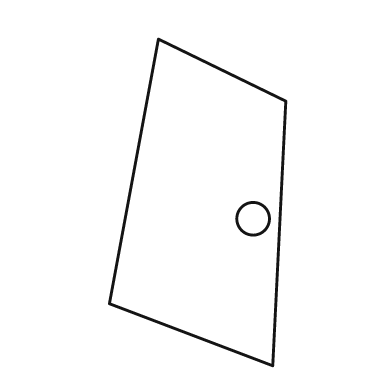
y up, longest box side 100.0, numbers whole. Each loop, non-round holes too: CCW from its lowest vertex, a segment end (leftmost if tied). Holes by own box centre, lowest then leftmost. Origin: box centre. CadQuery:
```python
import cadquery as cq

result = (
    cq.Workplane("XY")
    .moveTo(23.0, -50.0)
    .lineTo(27.0, 31.0)
    .lineTo(-12.0, 50.0)
    .lineTo(-27.0, -31.0)
    .close()
    .moveTo(17.0, -5.0)
    .circle(5.0)
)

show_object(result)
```